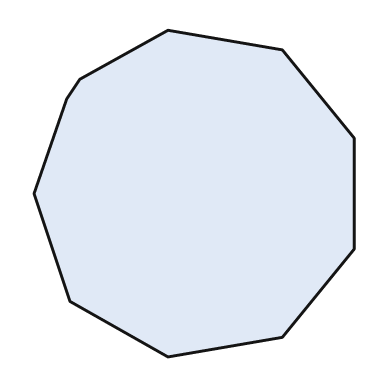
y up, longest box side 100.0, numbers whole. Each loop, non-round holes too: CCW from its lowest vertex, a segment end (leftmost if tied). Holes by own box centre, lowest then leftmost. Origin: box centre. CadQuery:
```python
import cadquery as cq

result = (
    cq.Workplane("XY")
    .moveTo(-8.0, -50.0)
    .lineTo(27.0, -44.0)
    .lineTo(49.0, -17.0)
    .lineTo(49.0, 17.0)
    .lineTo(27.0, 44.0)
    .lineTo(-8.0, 50.0)
    .lineTo(-35.0, 35.0)
    .lineTo(-39.0, 29.0)
    .lineTo(-49.0, 0.0)
    .lineTo(-38.0, -33.0)
    .close()
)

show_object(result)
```